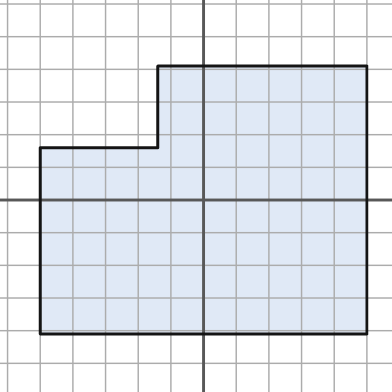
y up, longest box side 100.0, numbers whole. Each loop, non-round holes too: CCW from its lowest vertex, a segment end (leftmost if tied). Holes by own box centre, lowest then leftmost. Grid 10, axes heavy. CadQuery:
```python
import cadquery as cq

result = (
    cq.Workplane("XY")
    .moveTo(-50.0, -41.0)
    .lineTo(50.0, -41.0)
    .lineTo(50.0, 41.0)
    .lineTo(-14.0, 41.0)
    .lineTo(-14.0, 16.0)
    .lineTo(-50.0, 16.0)
    .close()
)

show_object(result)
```